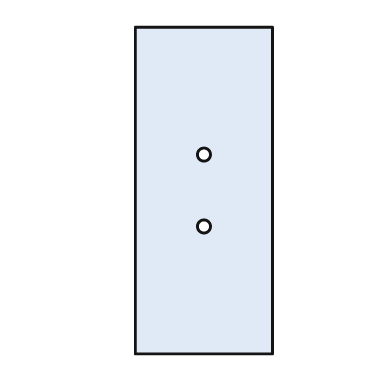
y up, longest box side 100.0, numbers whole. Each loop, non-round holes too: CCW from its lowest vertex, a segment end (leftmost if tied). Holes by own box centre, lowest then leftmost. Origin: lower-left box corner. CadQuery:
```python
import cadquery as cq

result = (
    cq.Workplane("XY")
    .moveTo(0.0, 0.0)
    .lineTo(42.0, 0.0)
    .lineTo(42.0, 100.0)
    .lineTo(0.0, 100.0)
    .close()
    .moveTo(21.0, 39.0)
    .circle(2.0)
    .moveTo(21.0, 61.0)
    .circle(2.0)
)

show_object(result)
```